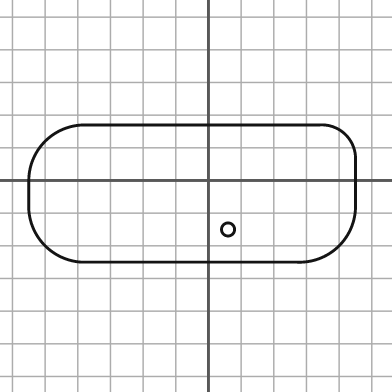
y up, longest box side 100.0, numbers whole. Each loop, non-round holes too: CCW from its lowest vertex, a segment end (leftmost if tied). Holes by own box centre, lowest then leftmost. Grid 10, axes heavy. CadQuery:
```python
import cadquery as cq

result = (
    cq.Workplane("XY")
    .moveTo(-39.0, -25.0)
    .lineTo(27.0, -25.0)
    .threePointArc((40.0, -20.0), (45.0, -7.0))
    .lineTo(45.0, 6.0)
    .threePointArc((42.0, 14.0), (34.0, 17.0))
    .lineTo(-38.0, 17.0)
    .threePointArc((-50.0, 12.0), (-55.0, 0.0))
    .lineTo(-55.0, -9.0)
    .threePointArc((-50.0, -20.0), (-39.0, -25.0))
    .close()
    .moveTo(6.0, -15.0)
    .circle(2.0)
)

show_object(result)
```